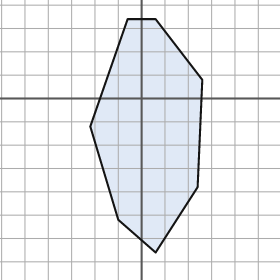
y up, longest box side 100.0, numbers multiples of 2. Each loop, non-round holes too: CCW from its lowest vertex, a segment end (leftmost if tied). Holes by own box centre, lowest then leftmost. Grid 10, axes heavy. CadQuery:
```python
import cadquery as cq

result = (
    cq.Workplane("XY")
    .moveTo(6.0, -66.0)
    .lineTo(24.0, -38.0)
    .lineTo(26.0, 8.0)
    .lineTo(6.0, 34.0)
    .lineTo(-6.0, 34.0)
    .lineTo(-22.0, -12.0)
    .lineTo(-10.0, -52.0)
    .close()
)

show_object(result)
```